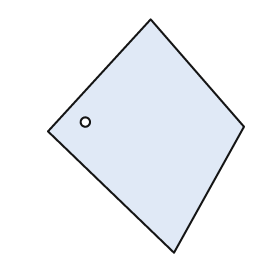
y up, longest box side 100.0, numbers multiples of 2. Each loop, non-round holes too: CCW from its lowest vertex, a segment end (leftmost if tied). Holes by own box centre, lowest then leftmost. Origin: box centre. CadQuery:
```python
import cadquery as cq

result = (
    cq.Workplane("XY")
    .moveTo(12.0, -50.0)
    .lineTo(42.0, 4.0)
    .lineTo(2.0, 50.0)
    .lineTo(-42.0, 2.0)
    .close()
    .moveTo(-26.0, 6.0)
    .circle(2.0)
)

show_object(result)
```